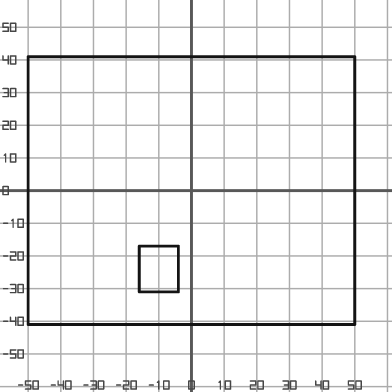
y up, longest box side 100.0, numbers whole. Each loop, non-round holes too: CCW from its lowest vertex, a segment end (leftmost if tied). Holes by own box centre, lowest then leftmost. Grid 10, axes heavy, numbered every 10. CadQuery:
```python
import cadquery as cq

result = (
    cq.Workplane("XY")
    .moveTo(-50.0, -41.0)
    .lineTo(50.0, -41.0)
    .lineTo(50.0, 41.0)
    .lineTo(-50.0, 41.0)
    .close()
    .moveTo(-16.0, -31.0)
    .lineTo(-4.0, -31.0)
    .lineTo(-4.0, -17.0)
    .lineTo(-16.0, -17.0)
    .close()
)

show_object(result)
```